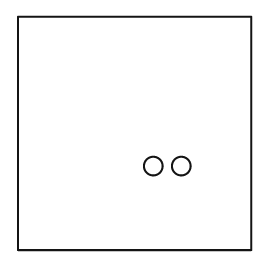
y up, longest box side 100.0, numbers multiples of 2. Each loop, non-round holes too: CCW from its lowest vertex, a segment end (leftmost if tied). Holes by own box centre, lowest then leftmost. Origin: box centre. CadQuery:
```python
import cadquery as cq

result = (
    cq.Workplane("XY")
    .moveTo(-50.0, -50.0)
    .lineTo(50.0, -50.0)
    .lineTo(50.0, 50.0)
    .lineTo(-50.0, 50.0)
    .close()
    .moveTo(8.0, -14.0)
    .circle(4.0)
    .moveTo(20.0, -14.0)
    .circle(4.0)
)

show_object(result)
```